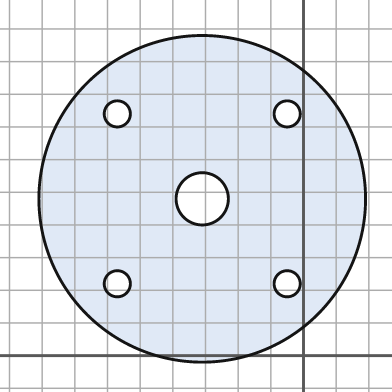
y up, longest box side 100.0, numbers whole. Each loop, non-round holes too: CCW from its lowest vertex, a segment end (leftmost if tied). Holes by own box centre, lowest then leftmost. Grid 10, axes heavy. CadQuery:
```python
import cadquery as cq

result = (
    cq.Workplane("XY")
    .moveTo(-31.0, 48.0)
    .circle(50.0)
    .moveTo(-57.0, 22.0)
    .circle(4.0)
    .moveTo(-5.0, 22.0)
    .circle(4.0)
    .moveTo(-31.0, 48.0)
    .circle(8.0)
    .moveTo(-57.0, 74.0)
    .circle(4.0)
    .moveTo(-5.0, 74.0)
    .circle(4.0)
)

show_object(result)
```